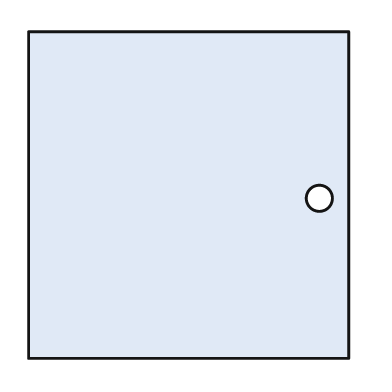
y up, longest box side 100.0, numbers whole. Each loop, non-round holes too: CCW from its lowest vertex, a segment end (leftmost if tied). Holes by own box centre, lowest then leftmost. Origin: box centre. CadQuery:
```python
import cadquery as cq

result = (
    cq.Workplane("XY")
    .moveTo(-49.0, -50.0)
    .lineTo(49.0, -50.0)
    .lineTo(49.0, 50.0)
    .lineTo(-49.0, 50.0)
    .close()
    .moveTo(40.0, -1.0)
    .circle(4.0)
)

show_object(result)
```